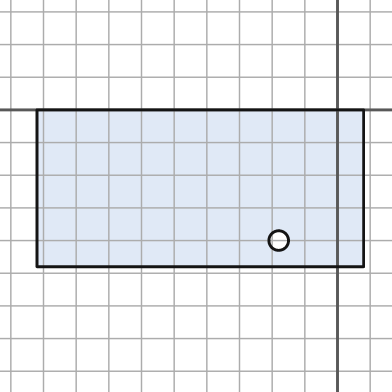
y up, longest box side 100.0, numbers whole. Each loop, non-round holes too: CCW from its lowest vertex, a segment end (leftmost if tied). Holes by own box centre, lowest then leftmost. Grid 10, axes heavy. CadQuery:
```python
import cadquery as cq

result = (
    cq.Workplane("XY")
    .moveTo(-92.0, -48.0)
    .lineTo(8.0, -48.0)
    .lineTo(8.0, 0.0)
    .lineTo(-92.0, 0.0)
    .close()
    .moveTo(-18.0, -40.0)
    .circle(3.0)
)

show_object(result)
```